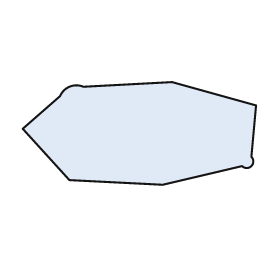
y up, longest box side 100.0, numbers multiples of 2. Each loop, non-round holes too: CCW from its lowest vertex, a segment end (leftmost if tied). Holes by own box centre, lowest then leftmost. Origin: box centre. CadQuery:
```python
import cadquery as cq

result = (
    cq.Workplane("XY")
    .moveTo(10.0, -22.0)
    .lineTo(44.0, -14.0)
    .threePointArc((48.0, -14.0), (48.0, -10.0))
    .lineTo(50.0, 12.0)
    .lineTo(14.0, 22.0)
    .lineTo(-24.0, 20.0)
    .threePointArc((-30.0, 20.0), (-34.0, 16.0))
    .lineTo(-50.0, 2.0)
    .lineTo(-30.0, -20.0)
    .close()
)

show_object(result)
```